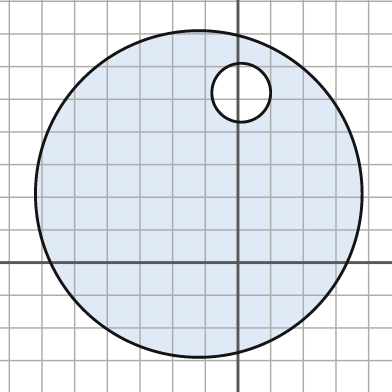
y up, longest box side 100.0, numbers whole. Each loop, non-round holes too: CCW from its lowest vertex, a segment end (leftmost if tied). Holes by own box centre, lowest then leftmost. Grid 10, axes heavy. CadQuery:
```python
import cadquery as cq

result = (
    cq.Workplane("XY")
    .moveTo(-12.0, 21.0)
    .circle(50.0)
    .moveTo(1.0, 52.0)
    .circle(9.0)
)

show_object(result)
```